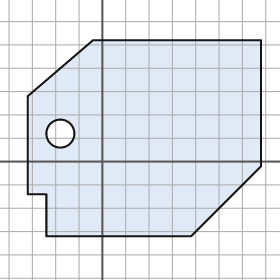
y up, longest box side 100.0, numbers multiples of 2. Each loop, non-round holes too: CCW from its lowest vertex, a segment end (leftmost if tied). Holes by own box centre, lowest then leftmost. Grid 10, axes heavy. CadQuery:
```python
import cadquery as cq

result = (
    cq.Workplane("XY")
    .moveTo(-24.0, -32.0)
    .lineTo(38.0, -32.0)
    .lineTo(68.0, -2.0)
    .lineTo(68.0, 52.0)
    .lineTo(-4.0, 52.0)
    .lineTo(-32.0, 28.0)
    .lineTo(-32.0, -14.0)
    .lineTo(-24.0, -14.0)
    .close()
    .moveTo(-18.0, 12.0)
    .circle(6.0)
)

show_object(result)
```